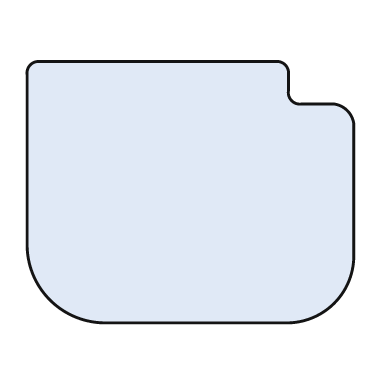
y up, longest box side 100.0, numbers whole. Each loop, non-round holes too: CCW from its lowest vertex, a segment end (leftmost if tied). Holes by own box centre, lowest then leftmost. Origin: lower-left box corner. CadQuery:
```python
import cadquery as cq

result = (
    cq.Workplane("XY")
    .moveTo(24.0, 0.0)
    .lineTo(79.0, 0.0)
    .threePointArc((94.0, 6.0), (100.0, 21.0))
    .lineTo(100.0, 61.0)
    .threePointArc((98.0, 65.0), (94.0, 67.0))
    .lineTo(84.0, 67.0)
    .threePointArc((81.0, 68.0), (80.0, 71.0))
    .lineTo(80.0, 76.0)
    .threePointArc((79.0, 79.0), (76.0, 80.0))
    .lineTo(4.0, 80.0)
    .threePointArc((1.0, 79.0), (0.0, 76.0))
    .lineTo(0.0, 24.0)
    .threePointArc((7.0, 7.0), (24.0, 0.0))
    .close()
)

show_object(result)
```